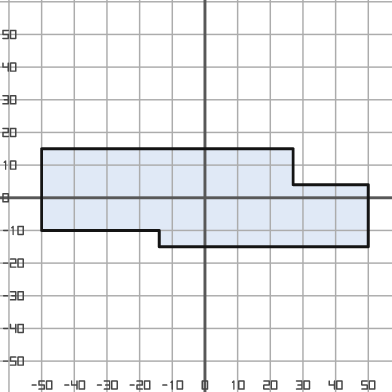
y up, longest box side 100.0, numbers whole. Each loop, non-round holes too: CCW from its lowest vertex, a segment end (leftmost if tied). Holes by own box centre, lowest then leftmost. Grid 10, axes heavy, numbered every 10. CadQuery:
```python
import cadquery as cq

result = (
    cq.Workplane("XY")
    .moveTo(-14.0, -15.0)
    .lineTo(50.0, -15.0)
    .lineTo(50.0, 4.0)
    .lineTo(27.0, 4.0)
    .lineTo(27.0, 15.0)
    .lineTo(-50.0, 15.0)
    .lineTo(-50.0, -10.0)
    .lineTo(-14.0, -10.0)
    .close()
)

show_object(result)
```